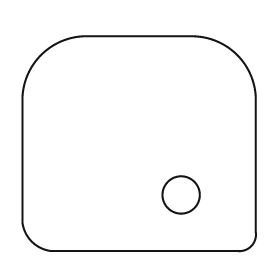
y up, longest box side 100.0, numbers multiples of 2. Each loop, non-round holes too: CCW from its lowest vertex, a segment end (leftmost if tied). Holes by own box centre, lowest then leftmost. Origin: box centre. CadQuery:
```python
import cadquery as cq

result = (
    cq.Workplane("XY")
    .moveTo(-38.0, -46.0)
    .lineTo(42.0, -46.0)
    .threePointArc((48.0, -44.0), (50.0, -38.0))
    .lineTo(50.0, 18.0)
    .threePointArc((42.0, 38.0), (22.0, 46.0))
    .lineTo(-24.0, 46.0)
    .threePointArc((-42.0, 38.0), (-50.0, 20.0))
    .lineTo(-50.0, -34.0)
    .threePointArc((-46.0, -42.0), (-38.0, -46.0))
    .close()
    .moveTo(18.0, -22.0)
    .circle(8.0)
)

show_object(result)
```